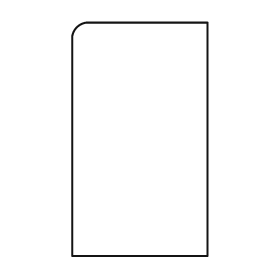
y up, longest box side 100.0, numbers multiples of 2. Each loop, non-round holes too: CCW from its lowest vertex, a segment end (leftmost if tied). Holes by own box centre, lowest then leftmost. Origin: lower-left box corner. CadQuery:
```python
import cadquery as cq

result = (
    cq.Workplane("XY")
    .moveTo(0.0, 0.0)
    .lineTo(58.0, 0.0)
    .lineTo(58.0, 100.0)
    .lineTo(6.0, 100.0)
    .threePointArc((2.0, 98.0), (0.0, 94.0))
    .close()
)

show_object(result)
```